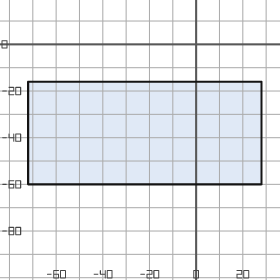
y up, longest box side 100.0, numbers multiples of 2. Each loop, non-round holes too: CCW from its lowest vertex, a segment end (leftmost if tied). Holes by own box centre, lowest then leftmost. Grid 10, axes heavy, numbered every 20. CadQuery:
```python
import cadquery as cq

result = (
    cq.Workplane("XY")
    .moveTo(-72.0, -60.0)
    .lineTo(28.0, -60.0)
    .lineTo(28.0, -16.0)
    .lineTo(-72.0, -16.0)
    .close()
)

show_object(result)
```